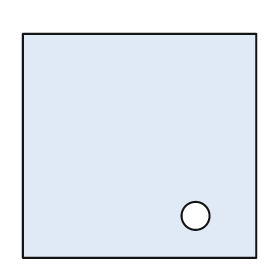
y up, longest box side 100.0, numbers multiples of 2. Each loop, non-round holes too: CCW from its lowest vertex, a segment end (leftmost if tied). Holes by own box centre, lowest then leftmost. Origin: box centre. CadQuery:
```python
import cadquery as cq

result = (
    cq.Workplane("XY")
    .moveTo(-50.0, -48.0)
    .lineTo(50.0, -48.0)
    .lineTo(50.0, 48.0)
    .lineTo(-50.0, 48.0)
    .close()
    .moveTo(24.0, -30.0)
    .circle(6.0)
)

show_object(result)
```